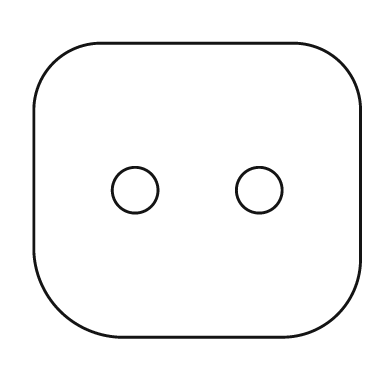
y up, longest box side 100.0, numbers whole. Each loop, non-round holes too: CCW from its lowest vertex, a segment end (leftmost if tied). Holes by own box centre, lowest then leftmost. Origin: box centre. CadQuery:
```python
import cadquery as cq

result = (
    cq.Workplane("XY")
    .moveTo(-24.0, -45.0)
    .lineTo(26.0, -45.0)
    .threePointArc((43.0, -38.0), (50.0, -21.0))
    .lineTo(50.0, 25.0)
    .threePointArc((44.0, 39.0), (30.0, 45.0))
    .lineTo(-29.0, 45.0)
    .threePointArc((-44.0, 39.0), (-50.0, 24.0))
    .lineTo(-50.0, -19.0)
    .threePointArc((-42.0, -37.0), (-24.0, -45.0))
    .close()
    .moveTo(-19.0, 0.0)
    .circle(7.0)
    .moveTo(19.0, 0.0)
    .circle(7.0)
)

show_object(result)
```